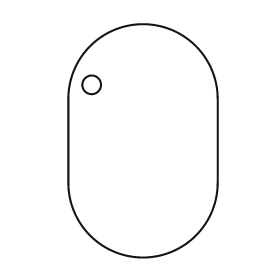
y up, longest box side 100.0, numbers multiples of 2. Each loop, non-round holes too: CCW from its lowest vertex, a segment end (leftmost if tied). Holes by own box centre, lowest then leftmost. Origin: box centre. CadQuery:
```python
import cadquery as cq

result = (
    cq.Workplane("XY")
    .moveTo(-32.0, -18.0)
    .threePointArc((0.0, -50.0), (32.0, -18.0))
    .lineTo(32.0, 18.0)
    .threePointArc((0.0, 50.0), (-32.0, 18.0))
    .close()
    .moveTo(-22.0, 24.0)
    .circle(4.0)
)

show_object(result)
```